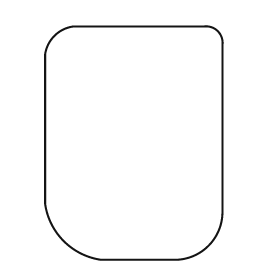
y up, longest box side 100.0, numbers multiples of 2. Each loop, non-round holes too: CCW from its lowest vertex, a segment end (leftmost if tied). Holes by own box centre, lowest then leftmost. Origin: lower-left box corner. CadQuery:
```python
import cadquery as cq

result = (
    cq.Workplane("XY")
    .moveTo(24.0, 0.0)
    .lineTo(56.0, 0.0)
    .threePointArc((70.0, 6.0), (76.0, 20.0))
    .lineTo(76.0, 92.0)
    .threePointArc((74.0, 98.0), (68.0, 100.0))
    .lineTo(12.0, 100.0)
    .threePointArc((4.0, 96.0), (0.0, 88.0))
    .lineTo(0.0, 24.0)
    .threePointArc((8.0, 8.0), (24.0, 0.0))
    .close()
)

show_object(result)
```